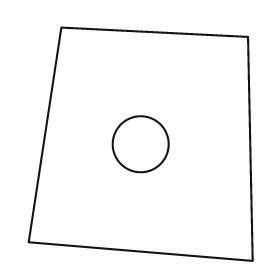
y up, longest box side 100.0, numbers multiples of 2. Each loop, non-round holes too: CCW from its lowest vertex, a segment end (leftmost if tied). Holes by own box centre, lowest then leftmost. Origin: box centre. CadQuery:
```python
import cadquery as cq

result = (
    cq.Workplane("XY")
    .moveTo(48.0, -50.0)
    .lineTo(46.0, 46.0)
    .lineTo(-34.0, 50.0)
    .lineTo(-48.0, -42.0)
    .close()
    .moveTo(0.0, 0.0)
    .circle(12.0)
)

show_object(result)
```